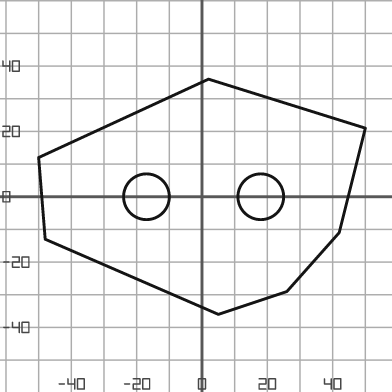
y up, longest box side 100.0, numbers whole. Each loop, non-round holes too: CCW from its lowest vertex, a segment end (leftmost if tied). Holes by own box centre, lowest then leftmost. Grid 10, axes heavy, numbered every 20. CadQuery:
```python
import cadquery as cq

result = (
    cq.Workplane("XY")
    .moveTo(5.0, -36.0)
    .lineTo(26.0, -29.0)
    .lineTo(42.0, -11.0)
    .lineTo(50.0, 21.0)
    .lineTo(2.0, 36.0)
    .lineTo(-50.0, 12.0)
    .lineTo(-48.0, -13.0)
    .close()
    .moveTo(-17.0, 0.0)
    .circle(7.0)
    .moveTo(18.0, 0.0)
    .circle(7.0)
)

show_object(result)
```